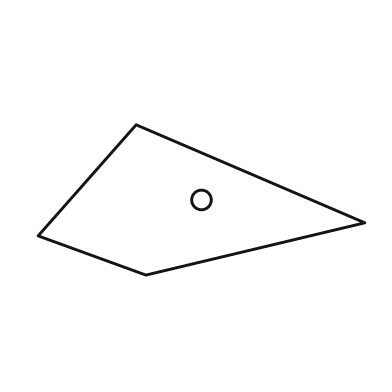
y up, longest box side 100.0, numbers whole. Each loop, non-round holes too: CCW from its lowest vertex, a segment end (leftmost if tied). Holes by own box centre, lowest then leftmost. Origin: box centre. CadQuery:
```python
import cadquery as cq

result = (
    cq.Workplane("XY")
    .moveTo(-17.0, -23.0)
    .lineTo(50.0, -7.0)
    .lineTo(-20.0, 23.0)
    .lineTo(-50.0, -11.0)
    .close()
    .moveTo(0.0, 0.0)
    .circle(3.0)
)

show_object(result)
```